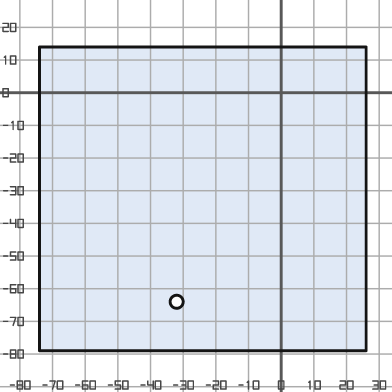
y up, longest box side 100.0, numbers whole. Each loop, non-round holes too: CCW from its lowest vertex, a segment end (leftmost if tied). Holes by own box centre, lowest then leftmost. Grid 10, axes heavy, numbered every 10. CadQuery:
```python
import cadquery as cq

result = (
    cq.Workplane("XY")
    .moveTo(-74.0, -79.0)
    .lineTo(26.0, -79.0)
    .lineTo(26.0, 14.0)
    .lineTo(-74.0, 14.0)
    .close()
    .moveTo(-32.0, -64.0)
    .circle(2.0)
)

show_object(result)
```